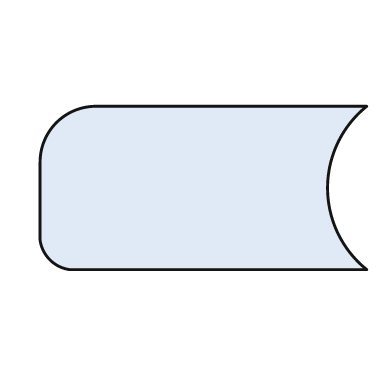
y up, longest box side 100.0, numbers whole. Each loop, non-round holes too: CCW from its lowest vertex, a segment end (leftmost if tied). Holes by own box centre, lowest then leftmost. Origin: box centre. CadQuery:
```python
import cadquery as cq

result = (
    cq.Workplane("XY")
    .moveTo(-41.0, -25.0)
    .lineTo(50.0, -25.0)
    .threePointArc((38.0, 0.0), (50.0, 25.0))
    .lineTo(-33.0, 25.0)
    .threePointArc((-45.0, 20.0), (-50.0, 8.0))
    .lineTo(-50.0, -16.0)
    .threePointArc((-47.0, -22.0), (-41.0, -25.0))
    .close()
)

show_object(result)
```